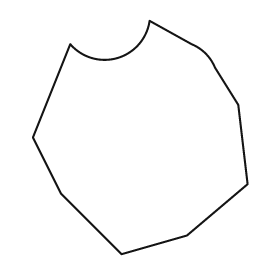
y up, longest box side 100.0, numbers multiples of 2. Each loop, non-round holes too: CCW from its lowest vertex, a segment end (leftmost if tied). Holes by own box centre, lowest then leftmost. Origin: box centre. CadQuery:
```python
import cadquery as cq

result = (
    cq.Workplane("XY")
    .moveTo(-8.0, -50.0)
    .lineTo(20.0, -42.0)
    .lineTo(46.0, -20.0)
    .lineTo(42.0, 14.0)
    .lineTo(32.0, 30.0)
    .threePointArc((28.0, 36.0), (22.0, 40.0))
    .lineTo(4.0, 50.0)
    .threePointArc((-10.0, 34.0), (-30.0, 40.0))
    .lineTo(-46.0, 0.0)
    .lineTo(-34.0, -24.0)
    .close()
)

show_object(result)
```